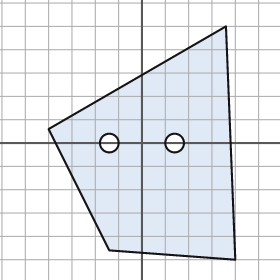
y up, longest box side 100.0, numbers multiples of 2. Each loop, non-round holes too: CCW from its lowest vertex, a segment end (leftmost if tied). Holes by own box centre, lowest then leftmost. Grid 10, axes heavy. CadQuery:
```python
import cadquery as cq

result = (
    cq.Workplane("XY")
    .moveTo(40.0, -50.0)
    .lineTo(36.0, 50.0)
    .lineTo(-40.0, 6.0)
    .lineTo(-14.0, -46.0)
    .close()
    .moveTo(-14.0, 0.0)
    .circle(4.0)
    .moveTo(14.0, 0.0)
    .circle(4.0)
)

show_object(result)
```